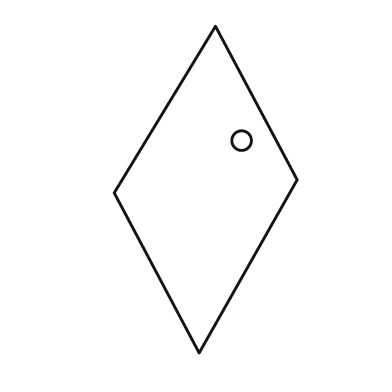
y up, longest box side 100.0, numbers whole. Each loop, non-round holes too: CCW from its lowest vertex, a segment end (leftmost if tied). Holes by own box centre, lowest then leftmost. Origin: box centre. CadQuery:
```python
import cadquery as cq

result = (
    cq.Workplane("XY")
    .moveTo(-2.0, -50.0)
    .lineTo(28.0, 3.0)
    .lineTo(3.0, 50.0)
    .lineTo(-28.0, -1.0)
    .close()
    .moveTo(11.0, 15.0)
    .circle(3.0)
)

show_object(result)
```